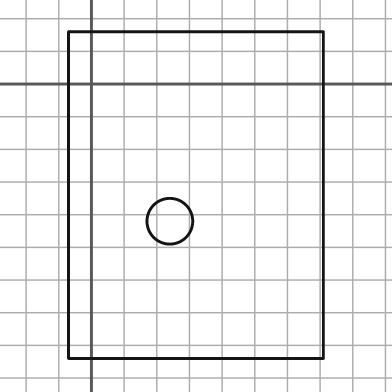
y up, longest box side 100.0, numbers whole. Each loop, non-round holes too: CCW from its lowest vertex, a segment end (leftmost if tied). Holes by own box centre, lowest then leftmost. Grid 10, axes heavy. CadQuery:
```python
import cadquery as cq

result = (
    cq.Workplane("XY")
    .moveTo(-7.0, -84.0)
    .lineTo(71.0, -84.0)
    .lineTo(71.0, 16.0)
    .lineTo(-7.0, 16.0)
    .close()
    .moveTo(24.0, -42.0)
    .circle(7.0)
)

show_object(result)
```